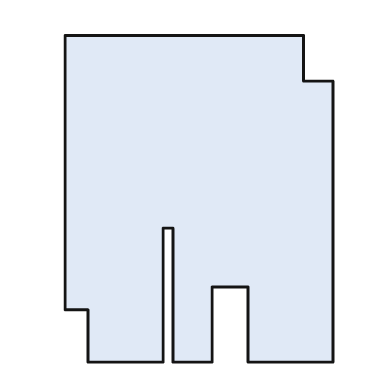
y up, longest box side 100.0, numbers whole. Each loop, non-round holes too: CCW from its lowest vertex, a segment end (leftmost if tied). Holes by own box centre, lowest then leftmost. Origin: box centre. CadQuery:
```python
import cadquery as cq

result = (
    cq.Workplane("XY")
    .moveTo(-34.0, -50.0)
    .lineTo(-11.0, -50.0)
    .lineTo(-11.0, -9.0)
    .lineTo(-8.0, -9.0)
    .lineTo(-8.0, -50.0)
    .lineTo(4.0, -50.0)
    .lineTo(4.0, -27.0)
    .lineTo(15.0, -27.0)
    .lineTo(15.0, -50.0)
    .lineTo(41.0, -50.0)
    .lineTo(41.0, 36.0)
    .lineTo(32.0, 36.0)
    .lineTo(32.0, 50.0)
    .lineTo(-41.0, 50.0)
    .lineTo(-41.0, -34.0)
    .lineTo(-34.0, -34.0)
    .close()
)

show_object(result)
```